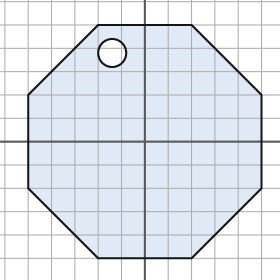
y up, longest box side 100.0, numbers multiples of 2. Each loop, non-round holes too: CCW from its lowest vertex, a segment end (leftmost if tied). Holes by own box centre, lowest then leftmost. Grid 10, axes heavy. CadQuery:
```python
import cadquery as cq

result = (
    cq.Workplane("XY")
    .moveTo(-20.0, -50.0)
    .lineTo(20.0, -50.0)
    .lineTo(50.0, -20.0)
    .lineTo(50.0, 20.0)
    .lineTo(20.0, 50.0)
    .lineTo(-20.0, 50.0)
    .lineTo(-50.0, 20.0)
    .lineTo(-50.0, -20.0)
    .close()
    .moveTo(-14.0, 38.0)
    .circle(6.0)
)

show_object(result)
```